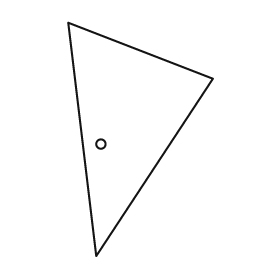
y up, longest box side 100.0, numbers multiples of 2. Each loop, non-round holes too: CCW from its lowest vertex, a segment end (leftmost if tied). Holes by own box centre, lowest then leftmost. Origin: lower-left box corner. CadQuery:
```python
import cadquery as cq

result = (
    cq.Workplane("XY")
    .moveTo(12.0, 0.0)
    .lineTo(62.0, 76.0)
    .lineTo(0.0, 100.0)
    .close()
    .moveTo(14.0, 48.0)
    .circle(2.0)
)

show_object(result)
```